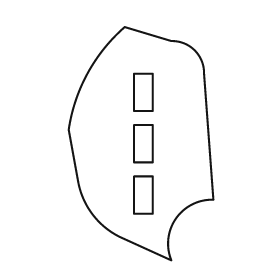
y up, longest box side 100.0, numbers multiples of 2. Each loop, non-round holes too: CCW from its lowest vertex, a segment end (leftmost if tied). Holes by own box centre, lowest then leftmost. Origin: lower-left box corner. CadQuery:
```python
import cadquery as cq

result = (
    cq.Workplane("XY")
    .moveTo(44.0, 0.0)
    .threePointArc((46.0, 18.0), (62.0, 26.0))
    .lineTo(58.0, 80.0)
    .threePointArc((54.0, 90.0), (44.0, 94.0))
    .lineTo(24.0, 100.0)
    .threePointArc((8.0, 80.0), (0.0, 56.0))
    .lineTo(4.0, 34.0)
    .threePointArc((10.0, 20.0), (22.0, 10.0))
    .close()
    .moveTo(28.0, 20.0)
    .lineTo(36.0, 20.0)
    .lineTo(36.0, 36.0)
    .lineTo(28.0, 36.0)
    .close()
    .moveTo(28.0, 42.0)
    .lineTo(36.0, 42.0)
    .lineTo(36.0, 58.0)
    .lineTo(28.0, 58.0)
    .close()
    .moveTo(28.0, 64.0)
    .lineTo(36.0, 64.0)
    .lineTo(36.0, 80.0)
    .lineTo(28.0, 80.0)
    .close()
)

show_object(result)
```